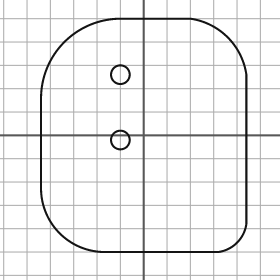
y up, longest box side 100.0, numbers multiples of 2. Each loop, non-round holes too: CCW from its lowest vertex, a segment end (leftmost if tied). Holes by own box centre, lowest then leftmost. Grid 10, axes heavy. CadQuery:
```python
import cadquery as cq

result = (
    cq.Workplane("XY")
    .moveTo(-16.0, -50.0)
    .lineTo(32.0, -50.0)
    .threePointArc((40.0, -46.0), (44.0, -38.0))
    .lineTo(44.0, 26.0)
    .threePointArc((36.0, 42.0), (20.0, 50.0))
    .lineTo(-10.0, 50.0)
    .threePointArc((-34.0, 40.0), (-44.0, 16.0))
    .lineTo(-44.0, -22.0)
    .threePointArc((-36.0, -42.0), (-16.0, -50.0))
    .close()
    .moveTo(-10.0, -2.0)
    .circle(4.0)
    .moveTo(-10.0, 26.0)
    .circle(4.0)
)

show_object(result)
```